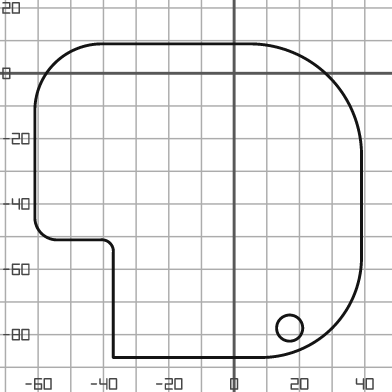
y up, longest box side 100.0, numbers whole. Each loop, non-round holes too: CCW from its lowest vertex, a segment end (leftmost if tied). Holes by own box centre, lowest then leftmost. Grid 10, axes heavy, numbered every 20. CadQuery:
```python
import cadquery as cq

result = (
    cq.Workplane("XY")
    .moveTo(-37.0, -87.0)
    .lineTo(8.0, -87.0)
    .threePointArc((30.0, -78.0), (39.0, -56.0))
    .lineTo(39.0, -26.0)
    .threePointArc((29.0, -1.0), (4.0, 9.0))
    .lineTo(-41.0, 9.0)
    .threePointArc((-55.0, 3.0), (-61.0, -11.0))
    .lineTo(-61.0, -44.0)
    .threePointArc((-59.0, -49.0), (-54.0, -51.0))
    .lineTo(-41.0, -51.0)
    .threePointArc((-38.0, -52.0), (-37.0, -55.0))
    .close()
    .moveTo(17.0, -78.0)
    .circle(4.0)
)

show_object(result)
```